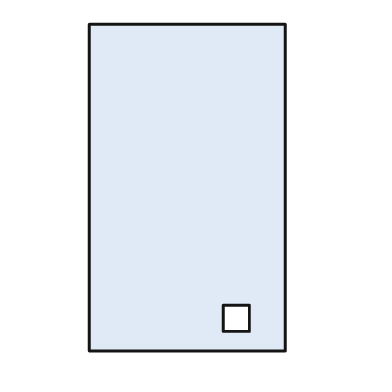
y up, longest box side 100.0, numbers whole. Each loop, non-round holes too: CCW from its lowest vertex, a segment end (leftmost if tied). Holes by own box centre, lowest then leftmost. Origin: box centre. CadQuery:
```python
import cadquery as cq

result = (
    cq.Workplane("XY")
    .moveTo(-30.0, -50.0)
    .lineTo(30.0, -50.0)
    .lineTo(30.0, 50.0)
    .lineTo(-30.0, 50.0)
    .close()
    .moveTo(11.0, -44.0)
    .lineTo(19.0, -44.0)
    .lineTo(19.0, -36.0)
    .lineTo(11.0, -36.0)
    .close()
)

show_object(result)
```